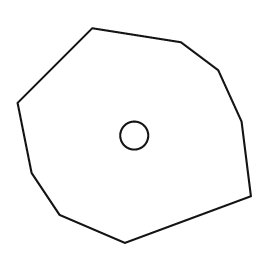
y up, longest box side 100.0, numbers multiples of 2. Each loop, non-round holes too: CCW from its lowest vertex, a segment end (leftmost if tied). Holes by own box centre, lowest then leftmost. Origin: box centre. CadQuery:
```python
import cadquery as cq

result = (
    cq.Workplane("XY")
    .moveTo(-4.0, -46.0)
    .lineTo(50.0, -26.0)
    .lineTo(46.0, 6.0)
    .lineTo(36.0, 28.0)
    .lineTo(20.0, 40.0)
    .lineTo(-18.0, 46.0)
    .lineTo(-50.0, 14.0)
    .lineTo(-44.0, -16.0)
    .lineTo(-32.0, -34.0)
    .close()
    .moveTo(0.0, 0.0)
    .circle(6.0)
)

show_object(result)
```